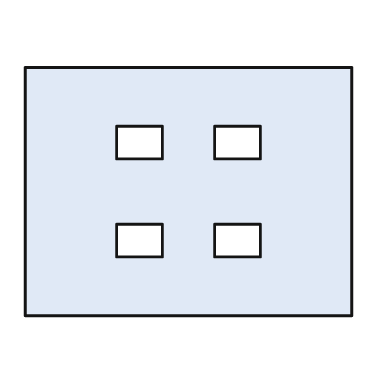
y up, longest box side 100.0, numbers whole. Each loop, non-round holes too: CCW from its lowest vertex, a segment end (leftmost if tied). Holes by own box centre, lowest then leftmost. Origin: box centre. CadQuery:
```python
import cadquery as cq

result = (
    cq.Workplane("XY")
    .moveTo(-50.0, -38.0)
    .lineTo(50.0, -38.0)
    .lineTo(50.0, 38.0)
    .lineTo(-50.0, 38.0)
    .close()
    .moveTo(-22.0, -20.0)
    .lineTo(-8.0, -20.0)
    .lineTo(-8.0, -10.0)
    .lineTo(-22.0, -10.0)
    .close()
    .moveTo(8.0, -20.0)
    .lineTo(22.0, -20.0)
    .lineTo(22.0, -10.0)
    .lineTo(8.0, -10.0)
    .close()
    .moveTo(-22.0, 10.0)
    .lineTo(-8.0, 10.0)
    .lineTo(-8.0, 20.0)
    .lineTo(-22.0, 20.0)
    .close()
    .moveTo(8.0, 10.0)
    .lineTo(22.0, 10.0)
    .lineTo(22.0, 20.0)
    .lineTo(8.0, 20.0)
    .close()
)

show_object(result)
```